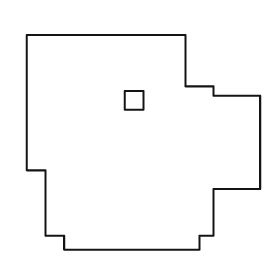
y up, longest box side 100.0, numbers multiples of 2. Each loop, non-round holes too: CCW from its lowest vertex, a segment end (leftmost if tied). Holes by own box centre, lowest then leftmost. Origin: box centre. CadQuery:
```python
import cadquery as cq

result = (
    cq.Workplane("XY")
    .moveTo(-34.0, -46.0)
    .lineTo(24.0, -46.0)
    .lineTo(24.0, -40.0)
    .lineTo(30.0, -40.0)
    .lineTo(30.0, -20.0)
    .lineTo(50.0, -20.0)
    .lineTo(50.0, 20.0)
    .lineTo(30.0, 20.0)
    .lineTo(30.0, 24.0)
    .lineTo(18.0, 24.0)
    .lineTo(18.0, 46.0)
    .lineTo(-50.0, 46.0)
    .lineTo(-50.0, -12.0)
    .lineTo(-42.0, -12.0)
    .lineTo(-42.0, -40.0)
    .lineTo(-34.0, -40.0)
    .close()
    .moveTo(-8.0, 14.0)
    .lineTo(0.0, 14.0)
    .lineTo(0.0, 22.0)
    .lineTo(-8.0, 22.0)
    .close()
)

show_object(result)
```